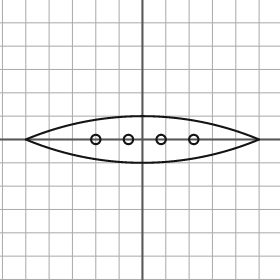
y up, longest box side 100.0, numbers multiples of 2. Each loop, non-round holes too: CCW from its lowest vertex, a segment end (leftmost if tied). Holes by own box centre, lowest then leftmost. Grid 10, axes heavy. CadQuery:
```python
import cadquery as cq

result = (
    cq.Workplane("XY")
    .moveTo(-50.0, 0.0)
    .threePointArc((0.0, -10.0), (50.0, 0.0))
    .threePointArc((0.0, 10.0), (-50.0, 0.0))
    .close()
    .moveTo(-20.0, 0.0)
    .circle(2.0)
    .moveTo(-6.0, 0.0)
    .circle(2.0)
    .moveTo(8.0, 0.0)
    .circle(2.0)
    .moveTo(22.0, 0.0)
    .circle(2.0)
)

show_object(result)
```